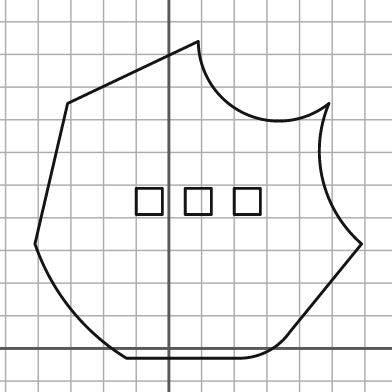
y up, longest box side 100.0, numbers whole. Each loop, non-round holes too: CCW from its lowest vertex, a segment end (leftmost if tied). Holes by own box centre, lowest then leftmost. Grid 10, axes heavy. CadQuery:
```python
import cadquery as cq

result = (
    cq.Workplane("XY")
    .moveTo(-13.0, -3.0)
    .lineTo(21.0, -3.0)
    .threePointArc((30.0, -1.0), (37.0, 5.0))
    .lineTo(59.0, 32.0)
    .threePointArc((47.0, 52.0), (49.0, 75.0))
    .threePointArc((23.0, 72.0), (9.0, 94.0))
    .lineTo(-31.0, 75.0)
    .lineTo(-41.0, 32.0)
    .threePointArc((-30.0, 12.0), (-13.0, -3.0))
    .close()
    .moveTo(-10.0, 41.0)
    .lineTo(-2.0, 41.0)
    .lineTo(-2.0, 49.0)
    .lineTo(-10.0, 49.0)
    .close()
    .moveTo(5.0, 41.0)
    .lineTo(13.0, 41.0)
    .lineTo(13.0, 49.0)
    .lineTo(5.0, 49.0)
    .close()
    .moveTo(20.0, 41.0)
    .lineTo(28.0, 41.0)
    .lineTo(28.0, 49.0)
    .lineTo(20.0, 49.0)
    .close()
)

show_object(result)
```